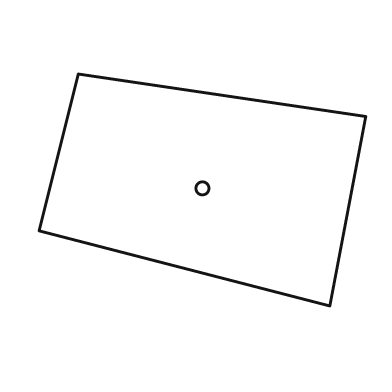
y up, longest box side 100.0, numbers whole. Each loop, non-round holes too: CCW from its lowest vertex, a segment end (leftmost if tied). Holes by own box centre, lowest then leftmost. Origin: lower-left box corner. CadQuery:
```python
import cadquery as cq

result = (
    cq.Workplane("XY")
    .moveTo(89.0, 0.0)
    .lineTo(100.0, 58.0)
    .lineTo(12.0, 71.0)
    .lineTo(0.0, 23.0)
    .close()
    .moveTo(50.0, 36.0)
    .circle(2.0)
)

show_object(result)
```